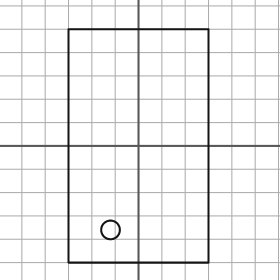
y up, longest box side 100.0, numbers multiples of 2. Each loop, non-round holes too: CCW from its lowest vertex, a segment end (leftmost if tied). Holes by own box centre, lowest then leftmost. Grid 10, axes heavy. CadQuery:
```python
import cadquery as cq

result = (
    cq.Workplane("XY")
    .moveTo(-30.0, -50.0)
    .lineTo(30.0, -50.0)
    .lineTo(30.0, 50.0)
    .lineTo(-30.0, 50.0)
    .close()
    .moveTo(-12.0, -36.0)
    .circle(4.0)
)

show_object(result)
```